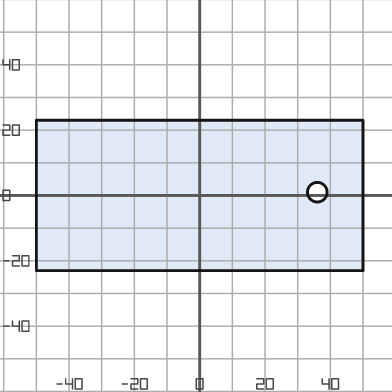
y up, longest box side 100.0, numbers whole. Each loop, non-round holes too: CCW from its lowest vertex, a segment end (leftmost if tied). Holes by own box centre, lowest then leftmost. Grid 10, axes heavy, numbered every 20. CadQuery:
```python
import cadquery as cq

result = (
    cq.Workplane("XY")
    .moveTo(-50.0, -23.0)
    .lineTo(50.0, -23.0)
    .lineTo(50.0, 23.0)
    .lineTo(-50.0, 23.0)
    .close()
    .moveTo(36.0, 1.0)
    .circle(3.0)
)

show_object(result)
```